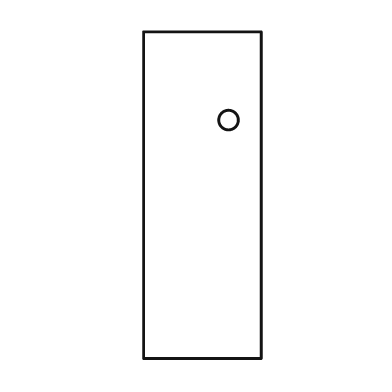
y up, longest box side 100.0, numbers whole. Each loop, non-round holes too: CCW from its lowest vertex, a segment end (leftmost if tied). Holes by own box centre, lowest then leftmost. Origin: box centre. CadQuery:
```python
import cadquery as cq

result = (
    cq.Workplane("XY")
    .moveTo(-18.0, -50.0)
    .lineTo(18.0, -50.0)
    .lineTo(18.0, 50.0)
    .lineTo(-18.0, 50.0)
    .close()
    .moveTo(8.0, 23.0)
    .circle(3.0)
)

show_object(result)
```